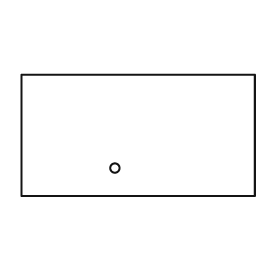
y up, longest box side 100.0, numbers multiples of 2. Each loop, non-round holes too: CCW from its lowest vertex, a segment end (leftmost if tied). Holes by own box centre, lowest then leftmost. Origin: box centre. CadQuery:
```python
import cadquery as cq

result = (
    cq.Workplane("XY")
    .moveTo(-50.0, -26.0)
    .lineTo(50.0, -26.0)
    .lineTo(50.0, 26.0)
    .lineTo(-50.0, 26.0)
    .close()
    .moveTo(-10.0, -14.0)
    .circle(2.0)
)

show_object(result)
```